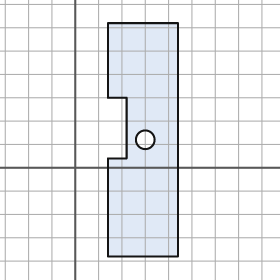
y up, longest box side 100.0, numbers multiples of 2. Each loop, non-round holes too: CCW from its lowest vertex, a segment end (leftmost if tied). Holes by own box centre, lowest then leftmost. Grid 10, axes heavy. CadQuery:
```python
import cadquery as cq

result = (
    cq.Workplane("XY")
    .moveTo(14.0, -38.0)
    .lineTo(44.0, -38.0)
    .lineTo(44.0, 62.0)
    .lineTo(14.0, 62.0)
    .lineTo(14.0, 30.0)
    .lineTo(22.0, 30.0)
    .lineTo(22.0, 4.0)
    .lineTo(14.0, 4.0)
    .close()
    .moveTo(30.0, 12.0)
    .circle(4.0)
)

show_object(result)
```